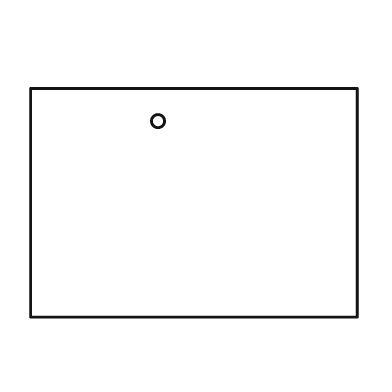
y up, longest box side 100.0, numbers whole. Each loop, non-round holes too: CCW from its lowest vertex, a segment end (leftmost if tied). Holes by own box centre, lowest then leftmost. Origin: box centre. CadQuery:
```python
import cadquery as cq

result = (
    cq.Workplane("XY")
    .moveTo(-50.0, -35.0)
    .lineTo(50.0, -35.0)
    .lineTo(50.0, 35.0)
    .lineTo(-50.0, 35.0)
    .close()
    .moveTo(-11.0, 25.0)
    .circle(2.0)
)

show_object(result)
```